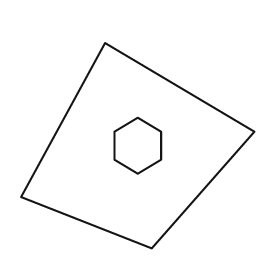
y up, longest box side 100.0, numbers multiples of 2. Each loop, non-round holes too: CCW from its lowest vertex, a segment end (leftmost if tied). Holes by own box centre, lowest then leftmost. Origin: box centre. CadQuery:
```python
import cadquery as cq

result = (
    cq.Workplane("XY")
    .moveTo(6.0, -44.0)
    .lineTo(50.0, 6.0)
    .lineTo(-14.0, 44.0)
    .lineTo(-50.0, -22.0)
    .close()
    .moveTo(0.0, -12.0)
    .lineTo(10.0, -6.0)
    .lineTo(10.0, 6.0)
    .lineTo(0.0, 12.0)
    .lineTo(-10.0, 6.0)
    .lineTo(-10.0, -6.0)
    .close()
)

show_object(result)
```